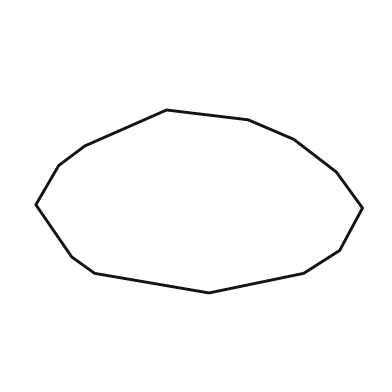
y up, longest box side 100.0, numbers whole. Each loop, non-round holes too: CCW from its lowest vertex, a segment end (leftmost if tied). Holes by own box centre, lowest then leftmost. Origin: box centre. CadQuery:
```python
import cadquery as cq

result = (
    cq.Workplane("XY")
    .moveTo(3.0, -28.0)
    .lineTo(32.0, -22.0)
    .lineTo(43.0, -15.0)
    .lineTo(50.0, -2.0)
    .lineTo(42.0, 9.0)
    .lineTo(29.0, 19.0)
    .lineTo(15.0, 25.0)
    .lineTo(-10.0, 28.0)
    .lineTo(-35.0, 17.0)
    .lineTo(-43.0, 11.0)
    .lineTo(-50.0, -1.0)
    .lineTo(-39.0, -17.0)
    .lineTo(-32.0, -22.0)
    .close()
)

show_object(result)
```